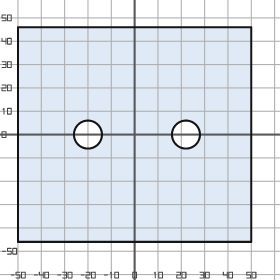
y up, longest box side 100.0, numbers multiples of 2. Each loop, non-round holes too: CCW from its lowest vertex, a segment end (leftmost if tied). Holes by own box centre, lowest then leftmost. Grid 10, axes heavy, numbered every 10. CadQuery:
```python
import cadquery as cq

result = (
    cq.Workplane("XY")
    .moveTo(-50.0, -46.0)
    .lineTo(50.0, -46.0)
    .lineTo(50.0, 46.0)
    .lineTo(-50.0, 46.0)
    .close()
    .moveTo(-20.0, 0.0)
    .circle(6.0)
    .moveTo(22.0, 0.0)
    .circle(6.0)
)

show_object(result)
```